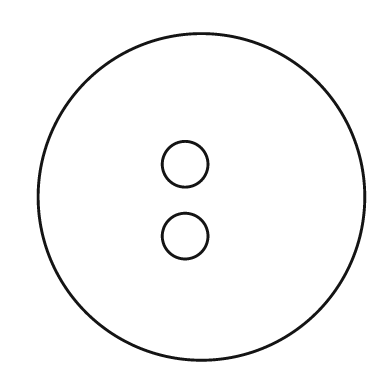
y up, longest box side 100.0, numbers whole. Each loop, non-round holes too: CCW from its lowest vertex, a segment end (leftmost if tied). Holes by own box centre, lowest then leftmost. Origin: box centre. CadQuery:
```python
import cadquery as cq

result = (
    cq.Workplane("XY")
    .moveTo(0.0, 0.0)
    .circle(50.0)
    .moveTo(-5.0, -12.0)
    .circle(7.0)
    .moveTo(-5.0, 10.0)
    .circle(7.0)
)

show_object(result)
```